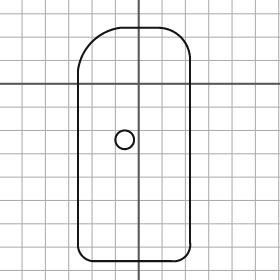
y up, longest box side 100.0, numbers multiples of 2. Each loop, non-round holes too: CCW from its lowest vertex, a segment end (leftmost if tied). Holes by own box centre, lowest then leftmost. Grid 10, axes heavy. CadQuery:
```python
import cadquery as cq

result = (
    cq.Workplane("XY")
    .moveTo(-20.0, -76.0)
    .lineTo(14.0, -76.0)
    .threePointArc((20.0, -74.0), (22.0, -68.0))
    .lineTo(22.0, 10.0)
    .threePointArc((18.0, 20.0), (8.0, 24.0))
    .lineTo(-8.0, 24.0)
    .threePointArc((-20.0, 18.0), (-26.0, 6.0))
    .lineTo(-26.0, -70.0)
    .threePointArc((-24.0, -74.0), (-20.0, -76.0))
    .close()
    .moveTo(-6.0, -24.0)
    .circle(4.0)
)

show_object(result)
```